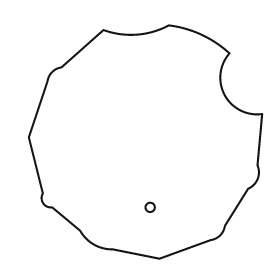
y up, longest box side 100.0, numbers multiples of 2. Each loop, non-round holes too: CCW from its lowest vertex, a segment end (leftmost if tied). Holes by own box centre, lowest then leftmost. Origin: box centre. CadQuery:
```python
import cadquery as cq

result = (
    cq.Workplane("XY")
    .moveTo(6.0, -50.0)
    .lineTo(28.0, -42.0)
    .threePointArc((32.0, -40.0), (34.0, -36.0))
    .lineTo(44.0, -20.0)
    .threePointArc((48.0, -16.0), (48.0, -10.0))
    .lineTo(50.0, 12.0)
    .threePointArc((34.0, 20.0), (36.0, 38.0))
    .threePointArc((24.0, 46.0), (10.0, 50.0))
    .threePointArc((-4.0, 46.0), (-18.0, 48.0))
    .lineTo(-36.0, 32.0)
    .threePointArc((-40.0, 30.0), (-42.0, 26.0))
    .lineTo(-50.0, 2.0)
    .lineTo(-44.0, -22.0)
    .threePointArc((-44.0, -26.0), (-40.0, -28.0))
    .lineTo(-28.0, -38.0)
    .threePointArc((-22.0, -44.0), (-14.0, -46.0))
    .close()
    .moveTo(2.0, -28.0)
    .circle(2.0)
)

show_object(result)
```